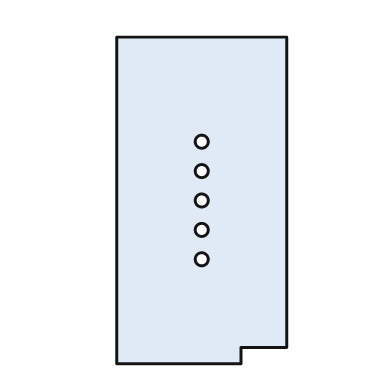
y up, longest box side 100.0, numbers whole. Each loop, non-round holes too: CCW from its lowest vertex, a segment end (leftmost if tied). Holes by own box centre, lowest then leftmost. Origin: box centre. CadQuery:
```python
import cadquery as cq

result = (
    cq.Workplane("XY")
    .moveTo(-26.0, -50.0)
    .lineTo(12.0, -50.0)
    .lineTo(12.0, -45.0)
    .lineTo(26.0, -45.0)
    .lineTo(26.0, 50.0)
    .lineTo(-26.0, 50.0)
    .close()
    .moveTo(0.0, -18.0)
    .circle(2.0)
    .moveTo(0.0, -9.0)
    .circle(2.0)
    .moveTo(0.0, 0.0)
    .circle(2.0)
    .moveTo(0.0, 9.0)
    .circle(2.0)
    .moveTo(0.0, 18.0)
    .circle(2.0)
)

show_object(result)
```